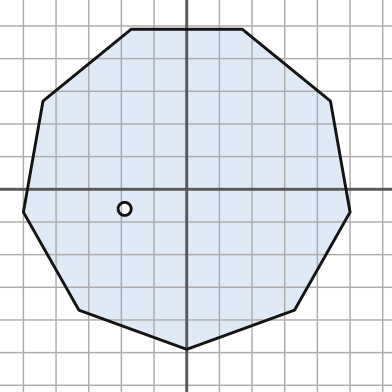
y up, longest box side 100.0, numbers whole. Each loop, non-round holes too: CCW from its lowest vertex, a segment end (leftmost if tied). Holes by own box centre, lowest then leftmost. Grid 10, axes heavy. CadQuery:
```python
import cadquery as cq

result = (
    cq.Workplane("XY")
    .moveTo(0.0, -49.0)
    .lineTo(33.0, -37.0)
    .lineTo(50.0, -7.0)
    .lineTo(44.0, 27.0)
    .lineTo(17.0, 49.0)
    .lineTo(-17.0, 49.0)
    .lineTo(-44.0, 27.0)
    .lineTo(-50.0, -7.0)
    .lineTo(-33.0, -37.0)
    .close()
    .moveTo(-19.0, -6.0)
    .circle(2.0)
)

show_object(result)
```